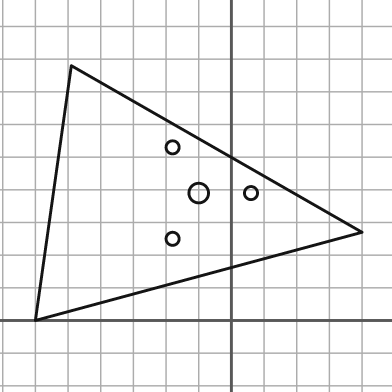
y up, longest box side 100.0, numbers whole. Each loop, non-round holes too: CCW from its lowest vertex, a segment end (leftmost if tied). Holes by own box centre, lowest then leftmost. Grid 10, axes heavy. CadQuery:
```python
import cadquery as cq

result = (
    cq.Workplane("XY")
    .moveTo(-60.0, 0.0)
    .lineTo(40.0, 27.0)
    .lineTo(-49.0, 78.0)
    .close()
    .moveTo(-18.0, 25.0)
    .circle(2.0)
    .moveTo(-10.0, 39.0)
    .circle(3.0)
    .moveTo(6.0, 39.0)
    .circle(2.0)
    .moveTo(-18.0, 53.0)
    .circle(2.0)
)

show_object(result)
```